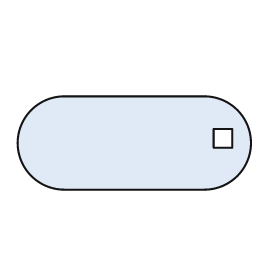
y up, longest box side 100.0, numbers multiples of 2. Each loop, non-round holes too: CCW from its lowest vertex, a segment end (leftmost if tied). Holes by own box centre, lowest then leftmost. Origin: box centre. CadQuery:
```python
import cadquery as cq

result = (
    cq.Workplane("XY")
    .moveTo(-30.0, -20.0)
    .lineTo(30.0, -20.0)
    .threePointArc((50.0, 0.0), (30.0, 20.0))
    .lineTo(-30.0, 20.0)
    .threePointArc((-50.0, 0.0), (-30.0, -20.0))
    .close()
    .moveTo(34.0, -2.0)
    .lineTo(42.0, -2.0)
    .lineTo(42.0, 6.0)
    .lineTo(34.0, 6.0)
    .close()
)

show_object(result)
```